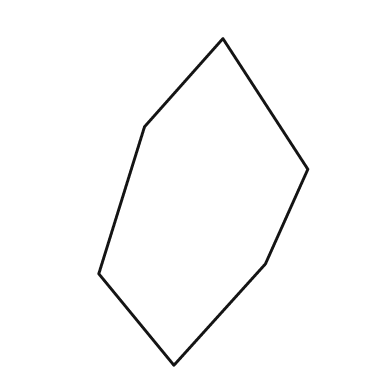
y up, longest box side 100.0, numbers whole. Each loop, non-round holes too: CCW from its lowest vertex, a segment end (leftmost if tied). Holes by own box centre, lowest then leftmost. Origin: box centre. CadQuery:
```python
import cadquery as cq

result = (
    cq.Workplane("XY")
    .moveTo(-9.0, -50.0)
    .lineTo(19.0, -19.0)
    .lineTo(32.0, 10.0)
    .lineTo(6.0, 50.0)
    .lineTo(-18.0, 23.0)
    .lineTo(-32.0, -22.0)
    .close()
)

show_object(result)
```